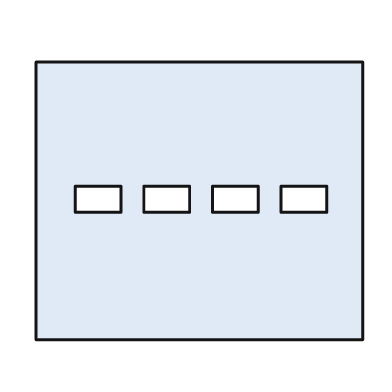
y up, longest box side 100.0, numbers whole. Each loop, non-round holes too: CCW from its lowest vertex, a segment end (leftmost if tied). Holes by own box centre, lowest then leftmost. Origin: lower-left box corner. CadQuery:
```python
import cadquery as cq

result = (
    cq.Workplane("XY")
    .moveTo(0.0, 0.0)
    .lineTo(100.0, 0.0)
    .lineTo(100.0, 85.0)
    .lineTo(0.0, 85.0)
    .close()
    .moveTo(12.0, 39.0)
    .lineTo(26.0, 39.0)
    .lineTo(26.0, 47.0)
    .lineTo(12.0, 47.0)
    .close()
    .moveTo(33.0, 39.0)
    .lineTo(47.0, 39.0)
    .lineTo(47.0, 47.0)
    .lineTo(33.0, 47.0)
    .close()
    .moveTo(54.0, 39.0)
    .lineTo(68.0, 39.0)
    .lineTo(68.0, 47.0)
    .lineTo(54.0, 47.0)
    .close()
    .moveTo(75.0, 39.0)
    .lineTo(89.0, 39.0)
    .lineTo(89.0, 47.0)
    .lineTo(75.0, 47.0)
    .close()
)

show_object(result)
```